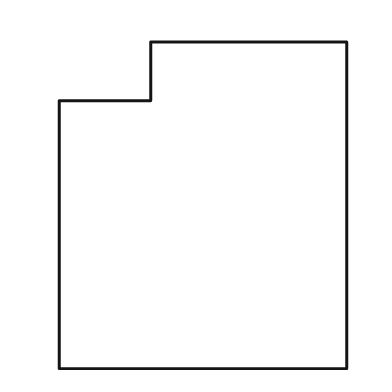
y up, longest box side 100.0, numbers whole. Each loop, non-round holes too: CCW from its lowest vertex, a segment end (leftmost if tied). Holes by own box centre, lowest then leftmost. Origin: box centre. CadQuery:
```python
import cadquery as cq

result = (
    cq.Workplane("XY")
    .moveTo(-44.0, -50.0)
    .lineTo(44.0, -50.0)
    .lineTo(44.0, 50.0)
    .lineTo(-16.0, 50.0)
    .lineTo(-16.0, 32.0)
    .lineTo(-44.0, 32.0)
    .close()
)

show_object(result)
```